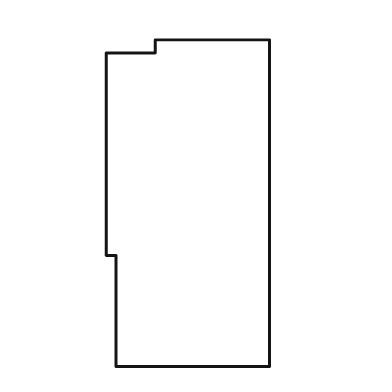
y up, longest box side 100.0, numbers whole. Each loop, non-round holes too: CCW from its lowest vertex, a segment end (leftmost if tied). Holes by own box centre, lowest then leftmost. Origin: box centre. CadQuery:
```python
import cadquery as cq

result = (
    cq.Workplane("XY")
    .moveTo(-22.0, -50.0)
    .lineTo(25.0, -50.0)
    .lineTo(25.0, 50.0)
    .lineTo(-10.0, 50.0)
    .lineTo(-10.0, 46.0)
    .lineTo(-25.0, 46.0)
    .lineTo(-25.0, -16.0)
    .lineTo(-22.0, -16.0)
    .close()
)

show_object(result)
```